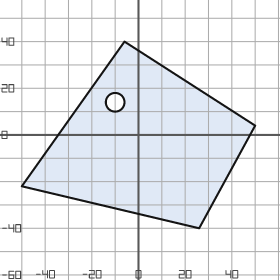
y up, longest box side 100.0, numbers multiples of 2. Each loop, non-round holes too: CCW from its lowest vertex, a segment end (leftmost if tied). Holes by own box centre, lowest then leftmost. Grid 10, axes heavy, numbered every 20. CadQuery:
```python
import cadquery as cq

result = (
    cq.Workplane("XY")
    .moveTo(26.0, -40.0)
    .lineTo(50.0, 4.0)
    .lineTo(-6.0, 40.0)
    .lineTo(-50.0, -22.0)
    .close()
    .moveTo(-10.0, 14.0)
    .circle(4.0)
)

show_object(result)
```